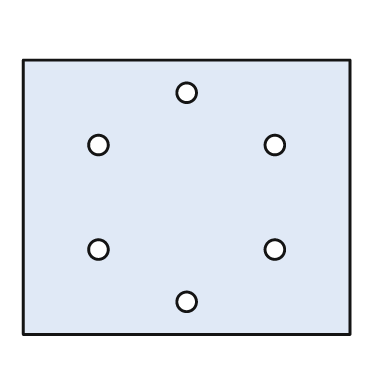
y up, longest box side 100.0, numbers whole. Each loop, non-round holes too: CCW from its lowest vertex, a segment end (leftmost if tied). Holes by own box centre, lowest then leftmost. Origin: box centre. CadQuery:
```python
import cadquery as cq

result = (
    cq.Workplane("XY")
    .moveTo(-50.0, -42.0)
    .lineTo(50.0, -42.0)
    .lineTo(50.0, 42.0)
    .lineTo(-50.0, 42.0)
    .close()
    .moveTo(0.0, -32.0)
    .circle(3.0)
    .moveTo(-27.0, -16.0)
    .circle(3.0)
    .moveTo(27.0, -16.0)
    .circle(3.0)
    .moveTo(-27.0, 16.0)
    .circle(3.0)
    .moveTo(27.0, 16.0)
    .circle(3.0)
    .moveTo(0.0, 32.0)
    .circle(3.0)
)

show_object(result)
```